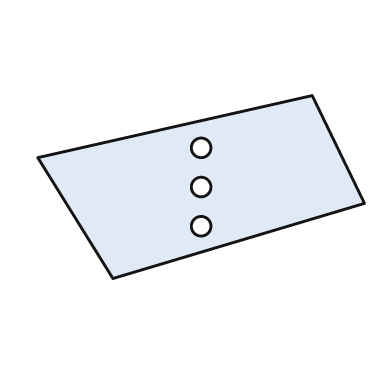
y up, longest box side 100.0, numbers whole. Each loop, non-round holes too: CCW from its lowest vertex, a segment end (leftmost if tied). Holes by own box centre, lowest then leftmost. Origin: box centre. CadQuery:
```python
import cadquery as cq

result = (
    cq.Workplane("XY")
    .moveTo(-27.0, -28.0)
    .lineTo(50.0, -5.0)
    .lineTo(34.0, 28.0)
    .lineTo(-50.0, 9.0)
    .close()
    .moveTo(0.0, -12.0)
    .circle(3.0)
    .moveTo(0.0, 0.0)
    .circle(3.0)
    .moveTo(0.0, 12.0)
    .circle(3.0)
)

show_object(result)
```